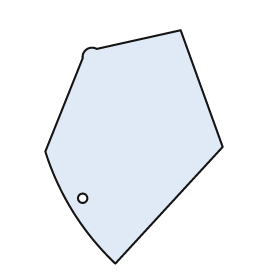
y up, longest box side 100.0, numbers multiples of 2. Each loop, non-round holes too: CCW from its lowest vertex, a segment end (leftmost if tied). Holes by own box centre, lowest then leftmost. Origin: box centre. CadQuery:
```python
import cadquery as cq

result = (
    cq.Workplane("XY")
    .moveTo(-8.0, -50.0)
    .lineTo(38.0, 0.0)
    .lineTo(20.0, 50.0)
    .lineTo(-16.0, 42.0)
    .threePointArc((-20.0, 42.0), (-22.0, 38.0))
    .lineTo(-38.0, -2.0)
    .threePointArc((-26.0, -28.0), (-8.0, -50.0))
    .close()
    .moveTo(-22.0, -22.0)
    .circle(2.0)
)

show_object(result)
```